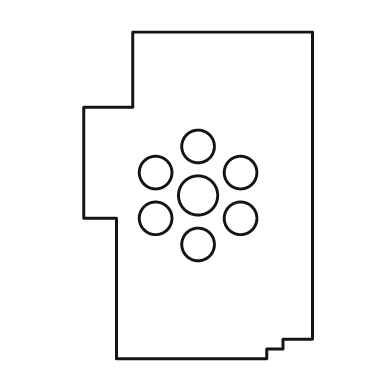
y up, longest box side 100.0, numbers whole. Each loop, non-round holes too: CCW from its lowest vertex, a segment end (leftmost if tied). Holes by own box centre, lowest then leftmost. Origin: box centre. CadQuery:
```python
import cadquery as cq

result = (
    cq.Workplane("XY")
    .moveTo(-25.0, -50.0)
    .lineTo(21.0, -50.0)
    .lineTo(21.0, -47.0)
    .lineTo(26.0, -47.0)
    .lineTo(26.0, -44.0)
    .lineTo(35.0, -44.0)
    .lineTo(35.0, 50.0)
    .lineTo(-20.0, 50.0)
    .lineTo(-20.0, 27.0)
    .lineTo(-35.0, 27.0)
    .lineTo(-35.0, -7.0)
    .lineTo(-25.0, -7.0)
    .close()
    .moveTo(0.0, -15.0)
    .circle(5.0)
    .moveTo(-13.0, -7.0)
    .circle(5.0)
    .moveTo(13.0, -7.0)
    .circle(5.0)
    .moveTo(0.0, 0.0)
    .circle(6.0)
    .moveTo(-13.0, 7.0)
    .circle(5.0)
    .moveTo(13.0, 7.0)
    .circle(5.0)
    .moveTo(0.0, 15.0)
    .circle(5.0)
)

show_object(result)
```